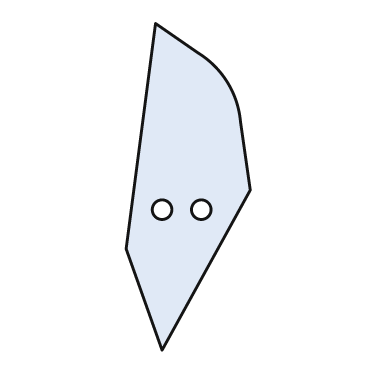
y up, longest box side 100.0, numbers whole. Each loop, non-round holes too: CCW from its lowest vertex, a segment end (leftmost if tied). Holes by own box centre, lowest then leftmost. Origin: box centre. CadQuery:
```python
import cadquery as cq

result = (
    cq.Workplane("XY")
    .moveTo(-8.0, -50.0)
    .lineTo(19.0, -1.0)
    .lineTo(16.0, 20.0)
    .threePointArc((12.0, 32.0), (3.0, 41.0))
    .lineTo(-10.0, 50.0)
    .lineTo(-19.0, -19.0)
    .close()
    .moveTo(-8.0, -7.0)
    .circle(3.0)
    .moveTo(4.0, -7.0)
    .circle(3.0)
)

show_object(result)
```